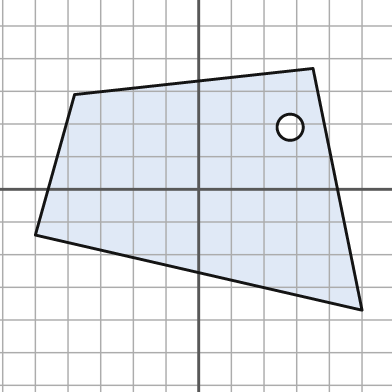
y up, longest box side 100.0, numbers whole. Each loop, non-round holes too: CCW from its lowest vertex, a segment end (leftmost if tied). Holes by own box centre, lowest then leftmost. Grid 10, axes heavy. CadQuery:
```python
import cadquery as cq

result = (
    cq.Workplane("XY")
    .moveTo(50.0, -37.0)
    .lineTo(35.0, 37.0)
    .lineTo(-38.0, 29.0)
    .lineTo(-50.0, -14.0)
    .close()
    .moveTo(28.0, 19.0)
    .circle(4.0)
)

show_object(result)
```